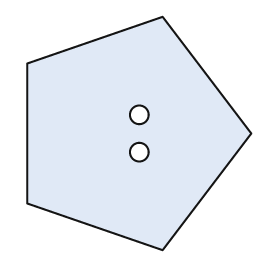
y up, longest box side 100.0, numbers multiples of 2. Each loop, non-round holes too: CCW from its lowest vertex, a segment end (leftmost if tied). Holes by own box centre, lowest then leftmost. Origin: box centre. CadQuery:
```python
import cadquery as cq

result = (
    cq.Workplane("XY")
    .moveTo(10.0, -50.0)
    .lineTo(48.0, 0.0)
    .lineTo(10.0, 50.0)
    .lineTo(-48.0, 30.0)
    .lineTo(-48.0, -30.0)
    .close()
    .moveTo(0.0, -8.0)
    .circle(4.0)
    .moveTo(0.0, 8.0)
    .circle(4.0)
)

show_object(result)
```